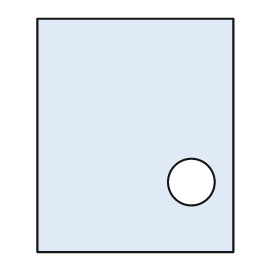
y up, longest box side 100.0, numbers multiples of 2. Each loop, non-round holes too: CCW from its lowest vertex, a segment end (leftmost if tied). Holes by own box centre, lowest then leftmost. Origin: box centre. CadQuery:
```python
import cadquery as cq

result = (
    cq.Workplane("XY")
    .moveTo(-42.0, -50.0)
    .lineTo(42.0, -50.0)
    .lineTo(42.0, 50.0)
    .lineTo(-42.0, 50.0)
    .close()
    .moveTo(24.0, -20.0)
    .circle(10.0)
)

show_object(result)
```